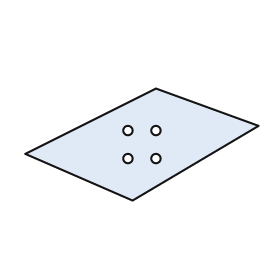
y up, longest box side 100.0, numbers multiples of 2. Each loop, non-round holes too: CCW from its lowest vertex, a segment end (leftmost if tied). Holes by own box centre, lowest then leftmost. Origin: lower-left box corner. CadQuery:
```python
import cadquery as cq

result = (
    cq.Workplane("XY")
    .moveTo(46.0, 0.0)
    .lineTo(100.0, 32.0)
    .lineTo(56.0, 48.0)
    .lineTo(0.0, 20.0)
    .close()
    .moveTo(44.0, 18.0)
    .circle(2.0)
    .moveTo(56.0, 18.0)
    .circle(2.0)
    .moveTo(44.0, 30.0)
    .circle(2.0)
    .moveTo(56.0, 30.0)
    .circle(2.0)
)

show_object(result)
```